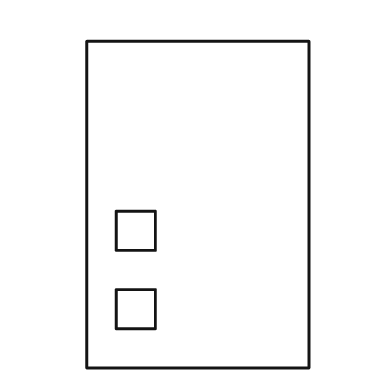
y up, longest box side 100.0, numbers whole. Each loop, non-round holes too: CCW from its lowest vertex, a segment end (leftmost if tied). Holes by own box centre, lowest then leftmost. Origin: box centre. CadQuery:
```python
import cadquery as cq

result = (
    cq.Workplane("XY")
    .moveTo(-34.0, -50.0)
    .lineTo(34.0, -50.0)
    .lineTo(34.0, 50.0)
    .lineTo(-34.0, 50.0)
    .close()
    .moveTo(-25.0, -38.0)
    .lineTo(-13.0, -38.0)
    .lineTo(-13.0, -26.0)
    .lineTo(-25.0, -26.0)
    .close()
    .moveTo(-25.0, -14.0)
    .lineTo(-13.0, -14.0)
    .lineTo(-13.0, -2.0)
    .lineTo(-25.0, -2.0)
    .close()
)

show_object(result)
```